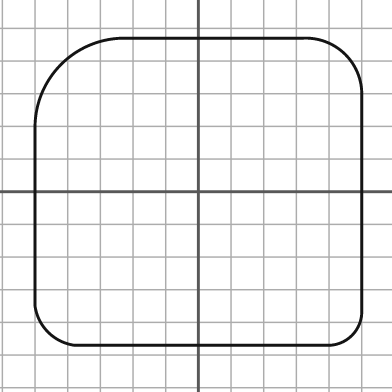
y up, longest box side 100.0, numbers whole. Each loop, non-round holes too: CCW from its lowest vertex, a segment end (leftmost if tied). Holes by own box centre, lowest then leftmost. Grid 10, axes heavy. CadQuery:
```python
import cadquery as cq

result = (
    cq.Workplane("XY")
    .moveTo(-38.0, -47.0)
    .lineTo(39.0, -47.0)
    .threePointArc((47.0, -44.0), (50.0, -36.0))
    .lineTo(50.0, 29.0)
    .threePointArc((45.0, 42.0), (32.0, 47.0))
    .lineTo(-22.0, 47.0)
    .threePointArc((-42.0, 39.0), (-50.0, 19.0))
    .lineTo(-50.0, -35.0)
    .threePointArc((-46.0, -43.0), (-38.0, -47.0))
    .close()
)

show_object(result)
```